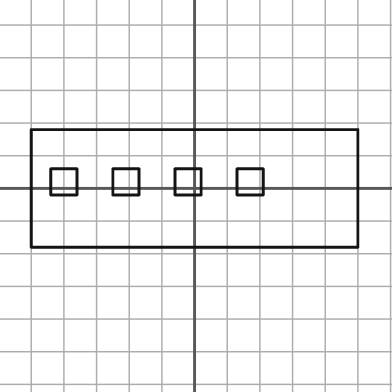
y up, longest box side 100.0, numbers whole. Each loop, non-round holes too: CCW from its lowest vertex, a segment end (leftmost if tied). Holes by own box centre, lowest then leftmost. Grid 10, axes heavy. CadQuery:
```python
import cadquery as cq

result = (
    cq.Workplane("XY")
    .moveTo(-50.0, -18.0)
    .lineTo(50.0, -18.0)
    .lineTo(50.0, 18.0)
    .lineTo(-50.0, 18.0)
    .close()
    .moveTo(-44.0, -2.0)
    .lineTo(-36.0, -2.0)
    .lineTo(-36.0, 6.0)
    .lineTo(-44.0, 6.0)
    .close()
    .moveTo(-25.0, -2.0)
    .lineTo(-17.0, -2.0)
    .lineTo(-17.0, 6.0)
    .lineTo(-25.0, 6.0)
    .close()
    .moveTo(-6.0, -2.0)
    .lineTo(2.0, -2.0)
    .lineTo(2.0, 6.0)
    .lineTo(-6.0, 6.0)
    .close()
    .moveTo(13.0, -2.0)
    .lineTo(21.0, -2.0)
    .lineTo(21.0, 6.0)
    .lineTo(13.0, 6.0)
    .close()
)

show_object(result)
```